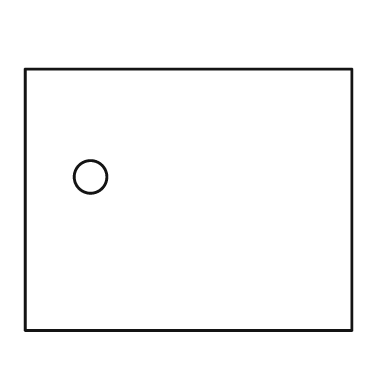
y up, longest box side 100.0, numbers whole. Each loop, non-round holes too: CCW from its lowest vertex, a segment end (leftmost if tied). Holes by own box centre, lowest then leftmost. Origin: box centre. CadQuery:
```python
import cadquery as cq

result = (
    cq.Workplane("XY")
    .moveTo(-50.0, -40.0)
    .lineTo(50.0, -40.0)
    .lineTo(50.0, 40.0)
    .lineTo(-50.0, 40.0)
    .close()
    .moveTo(-30.0, 7.0)
    .circle(5.0)
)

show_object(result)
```